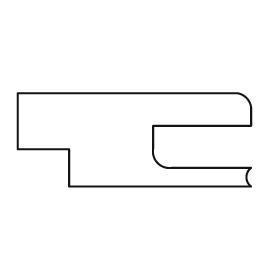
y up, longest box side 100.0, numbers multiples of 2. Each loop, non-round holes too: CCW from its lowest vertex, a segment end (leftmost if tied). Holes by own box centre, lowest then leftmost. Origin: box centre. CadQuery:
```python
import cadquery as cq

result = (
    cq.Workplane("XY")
    .moveTo(-28.0, -20.0)
    .lineTo(50.0, -20.0)
    .threePointArc((48.0, -16.0), (50.0, -12.0))
    .lineTo(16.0, -12.0)
    .threePointArc((10.0, -10.0), (8.0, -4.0))
    .lineTo(8.0, 6.0)
    .lineTo(50.0, 6.0)
    .lineTo(50.0, 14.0)
    .threePointArc((48.0, 18.0), (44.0, 20.0))
    .lineTo(-50.0, 20.0)
    .lineTo(-50.0, -4.0)
    .lineTo(-28.0, -4.0)
    .close()
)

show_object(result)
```